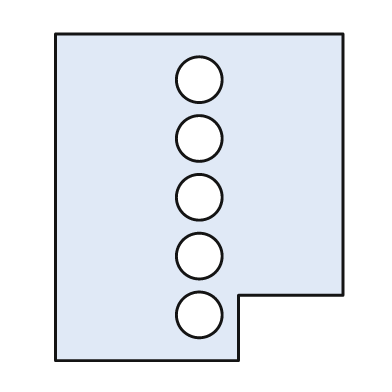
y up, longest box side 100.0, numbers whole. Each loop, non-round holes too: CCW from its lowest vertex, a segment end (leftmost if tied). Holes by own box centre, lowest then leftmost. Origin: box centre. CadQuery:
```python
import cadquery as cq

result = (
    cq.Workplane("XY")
    .moveTo(-44.0, -50.0)
    .lineTo(12.0, -50.0)
    .lineTo(12.0, -30.0)
    .lineTo(44.0, -30.0)
    .lineTo(44.0, 50.0)
    .lineTo(-44.0, 50.0)
    .close()
    .moveTo(0.0, -36.0)
    .circle(7.0)
    .moveTo(0.0, -18.0)
    .circle(7.0)
    .moveTo(0.0, 0.0)
    .circle(7.0)
    .moveTo(0.0, 18.0)
    .circle(7.0)
    .moveTo(0.0, 36.0)
    .circle(7.0)
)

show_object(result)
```